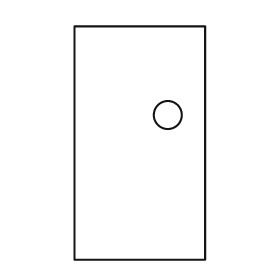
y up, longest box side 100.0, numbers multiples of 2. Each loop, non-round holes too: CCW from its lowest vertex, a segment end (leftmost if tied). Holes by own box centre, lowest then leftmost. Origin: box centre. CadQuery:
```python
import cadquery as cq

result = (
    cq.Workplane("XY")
    .moveTo(-28.0, -50.0)
    .lineTo(28.0, -50.0)
    .lineTo(28.0, 50.0)
    .lineTo(-28.0, 50.0)
    .close()
    .moveTo(12.0, 12.0)
    .circle(6.0)
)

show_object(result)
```